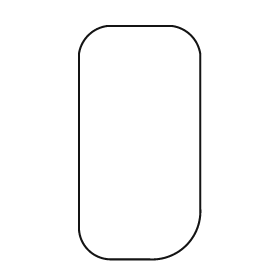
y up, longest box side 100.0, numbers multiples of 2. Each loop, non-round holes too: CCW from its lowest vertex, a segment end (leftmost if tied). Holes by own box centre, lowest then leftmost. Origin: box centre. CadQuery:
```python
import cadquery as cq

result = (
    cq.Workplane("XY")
    .moveTo(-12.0, -50.0)
    .lineTo(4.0, -50.0)
    .threePointArc((20.0, -44.0), (26.0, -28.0))
    .lineTo(26.0, 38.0)
    .threePointArc((22.0, 46.0), (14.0, 50.0))
    .lineTo(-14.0, 50.0)
    .threePointArc((-22.0, 46.0), (-26.0, 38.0))
    .lineTo(-26.0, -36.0)
    .threePointArc((-22.0, -46.0), (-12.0, -50.0))
    .close()
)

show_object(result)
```